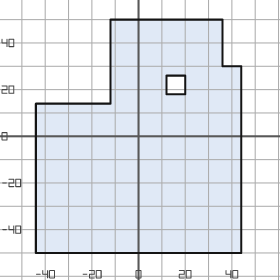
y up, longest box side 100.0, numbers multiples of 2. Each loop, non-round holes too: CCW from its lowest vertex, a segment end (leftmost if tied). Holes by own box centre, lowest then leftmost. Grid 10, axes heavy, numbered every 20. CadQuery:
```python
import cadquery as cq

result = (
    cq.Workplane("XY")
    .moveTo(-44.0, -50.0)
    .lineTo(44.0, -50.0)
    .lineTo(44.0, 30.0)
    .lineTo(36.0, 30.0)
    .lineTo(36.0, 50.0)
    .lineTo(-12.0, 50.0)
    .lineTo(-12.0, 14.0)
    .lineTo(-44.0, 14.0)
    .close()
    .moveTo(12.0, 18.0)
    .lineTo(20.0, 18.0)
    .lineTo(20.0, 26.0)
    .lineTo(12.0, 26.0)
    .close()
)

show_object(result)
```